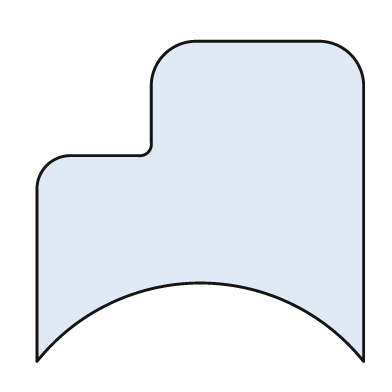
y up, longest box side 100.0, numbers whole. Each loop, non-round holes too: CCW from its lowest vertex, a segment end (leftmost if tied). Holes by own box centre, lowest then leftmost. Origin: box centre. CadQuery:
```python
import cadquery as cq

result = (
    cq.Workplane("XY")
    .moveTo(-50.0, -49.0)
    .threePointArc((0.0, -25.0), (50.0, -49.0))
    .lineTo(50.0, 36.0)
    .threePointArc((46.0, 45.0), (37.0, 49.0))
    .lineTo(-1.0, 49.0)
    .threePointArc((-11.0, 45.0), (-15.0, 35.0))
    .lineTo(-15.0, 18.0)
    .threePointArc((-16.0, 15.0), (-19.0, 14.0))
    .lineTo(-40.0, 14.0)
    .threePointArc((-47.0, 11.0), (-50.0, 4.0))
    .close()
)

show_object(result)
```